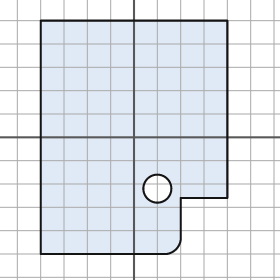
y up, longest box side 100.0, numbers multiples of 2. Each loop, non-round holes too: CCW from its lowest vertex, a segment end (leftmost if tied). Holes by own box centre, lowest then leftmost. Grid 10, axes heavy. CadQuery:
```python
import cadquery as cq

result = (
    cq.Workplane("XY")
    .moveTo(-40.0, -50.0)
    .lineTo(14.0, -50.0)
    .threePointArc((18.0, -48.0), (20.0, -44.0))
    .lineTo(20.0, -26.0)
    .lineTo(40.0, -26.0)
    .lineTo(40.0, 50.0)
    .lineTo(-40.0, 50.0)
    .close()
    .moveTo(10.0, -22.0)
    .circle(6.0)
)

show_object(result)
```